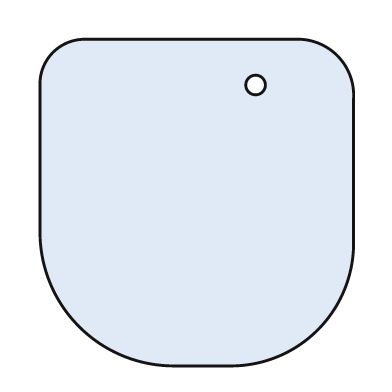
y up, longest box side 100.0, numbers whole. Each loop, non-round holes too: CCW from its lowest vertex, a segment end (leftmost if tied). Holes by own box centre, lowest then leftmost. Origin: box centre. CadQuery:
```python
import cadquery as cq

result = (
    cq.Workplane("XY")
    .moveTo(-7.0, -50.0)
    .lineTo(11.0, -50.0)
    .threePointArc((37.0, -39.0), (48.0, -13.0))
    .lineTo(48.0, 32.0)
    .threePointArc((43.0, 45.0), (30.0, 50.0))
    .lineTo(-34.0, 50.0)
    .threePointArc((-44.0, 46.0), (-48.0, 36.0))
    .lineTo(-48.0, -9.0)
    .threePointArc((-36.0, -38.0), (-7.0, -50.0))
    .close()
    .moveTo(18.0, 36.0)
    .circle(3.0)
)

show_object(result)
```